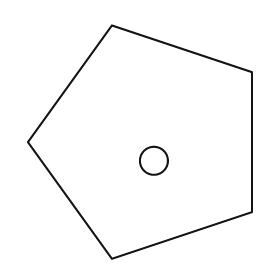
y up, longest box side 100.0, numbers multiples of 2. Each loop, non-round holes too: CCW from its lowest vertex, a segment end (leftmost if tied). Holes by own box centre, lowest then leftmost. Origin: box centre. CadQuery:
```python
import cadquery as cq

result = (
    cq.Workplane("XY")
    .moveTo(-12.0, -50.0)
    .lineTo(48.0, -30.0)
    .lineTo(48.0, 30.0)
    .lineTo(-12.0, 50.0)
    .lineTo(-48.0, 0.0)
    .close()
    .moveTo(6.0, -8.0)
    .circle(6.0)
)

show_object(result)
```